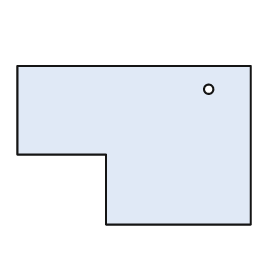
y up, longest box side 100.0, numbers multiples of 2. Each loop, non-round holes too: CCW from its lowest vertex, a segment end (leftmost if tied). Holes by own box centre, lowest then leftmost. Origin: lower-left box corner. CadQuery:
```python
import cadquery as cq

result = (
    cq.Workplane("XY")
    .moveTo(38.0, 0.0)
    .lineTo(100.0, 0.0)
    .lineTo(100.0, 68.0)
    .lineTo(0.0, 68.0)
    .lineTo(0.0, 30.0)
    .lineTo(38.0, 30.0)
    .close()
    .moveTo(82.0, 58.0)
    .circle(2.0)
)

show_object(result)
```